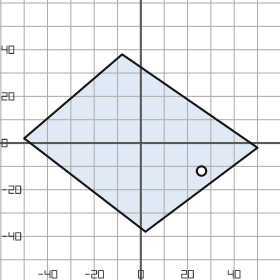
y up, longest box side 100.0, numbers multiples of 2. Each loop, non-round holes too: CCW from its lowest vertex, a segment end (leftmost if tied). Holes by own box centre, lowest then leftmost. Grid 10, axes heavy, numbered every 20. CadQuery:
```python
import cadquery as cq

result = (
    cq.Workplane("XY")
    .moveTo(2.0, -38.0)
    .lineTo(50.0, -2.0)
    .lineTo(-8.0, 38.0)
    .lineTo(-50.0, 2.0)
    .close()
    .moveTo(26.0, -12.0)
    .circle(2.0)
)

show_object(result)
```